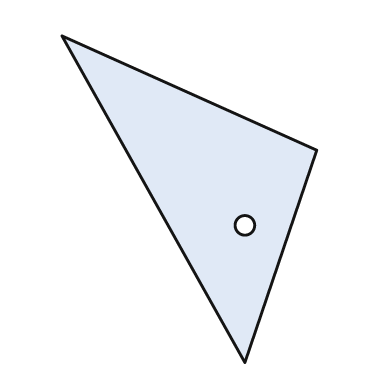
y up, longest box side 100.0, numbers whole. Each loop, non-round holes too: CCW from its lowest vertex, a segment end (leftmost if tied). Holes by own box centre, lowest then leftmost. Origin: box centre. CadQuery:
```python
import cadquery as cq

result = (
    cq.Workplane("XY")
    .moveTo(17.0, -50.0)
    .lineTo(39.0, 15.0)
    .lineTo(-39.0, 50.0)
    .close()
    .moveTo(17.0, -8.0)
    .circle(3.0)
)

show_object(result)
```